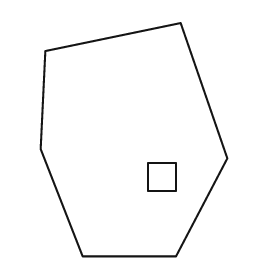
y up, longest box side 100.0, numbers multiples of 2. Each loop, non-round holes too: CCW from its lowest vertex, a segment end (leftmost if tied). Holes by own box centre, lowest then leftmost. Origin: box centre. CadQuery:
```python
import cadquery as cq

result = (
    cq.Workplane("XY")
    .moveTo(-22.0, -50.0)
    .lineTo(18.0, -50.0)
    .lineTo(40.0, -8.0)
    .lineTo(20.0, 50.0)
    .lineTo(-38.0, 38.0)
    .lineTo(-40.0, -4.0)
    .close()
    .moveTo(6.0, -22.0)
    .lineTo(18.0, -22.0)
    .lineTo(18.0, -10.0)
    .lineTo(6.0, -10.0)
    .close()
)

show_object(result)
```